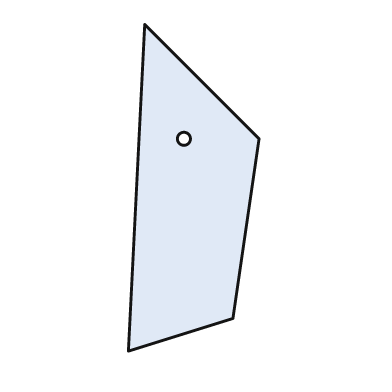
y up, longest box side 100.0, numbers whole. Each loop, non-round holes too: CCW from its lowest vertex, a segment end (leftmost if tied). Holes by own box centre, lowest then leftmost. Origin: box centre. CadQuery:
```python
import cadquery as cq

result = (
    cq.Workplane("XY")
    .moveTo(-20.0, -50.0)
    .lineTo(12.0, -40.0)
    .lineTo(20.0, 15.0)
    .lineTo(-15.0, 50.0)
    .close()
    .moveTo(-3.0, 15.0)
    .circle(2.0)
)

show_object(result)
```